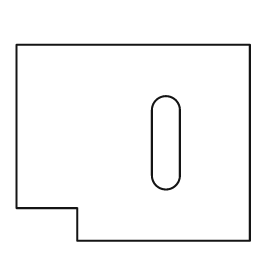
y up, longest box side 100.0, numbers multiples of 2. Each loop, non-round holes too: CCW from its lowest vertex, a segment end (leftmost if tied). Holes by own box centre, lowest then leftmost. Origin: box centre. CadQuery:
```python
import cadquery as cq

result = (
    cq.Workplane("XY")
    .moveTo(-24.0, -42.0)
    .lineTo(50.0, -42.0)
    .lineTo(50.0, 42.0)
    .lineTo(-50.0, 42.0)
    .lineTo(-50.0, -28.0)
    .lineTo(-24.0, -28.0)
    .close()
    .moveTo(8.0, -14.0)
    .threePointArc((14.0, -20.0), (20.0, -14.0))
    .lineTo(20.0, 14.0)
    .threePointArc((14.0, 20.0), (8.0, 14.0))
    .close()
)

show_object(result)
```